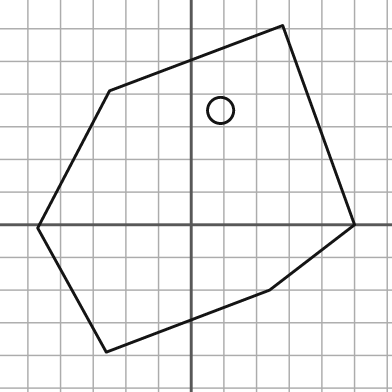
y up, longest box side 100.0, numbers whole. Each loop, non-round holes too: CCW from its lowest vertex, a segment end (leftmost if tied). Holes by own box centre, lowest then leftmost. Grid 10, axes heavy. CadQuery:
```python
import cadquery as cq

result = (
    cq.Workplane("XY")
    .moveTo(-26.0, -39.0)
    .lineTo(24.0, -20.0)
    .lineTo(50.0, 0.0)
    .lineTo(28.0, 61.0)
    .lineTo(-25.0, 41.0)
    .lineTo(-47.0, -1.0)
    .close()
    .moveTo(9.0, 35.0)
    .circle(4.0)
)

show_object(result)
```